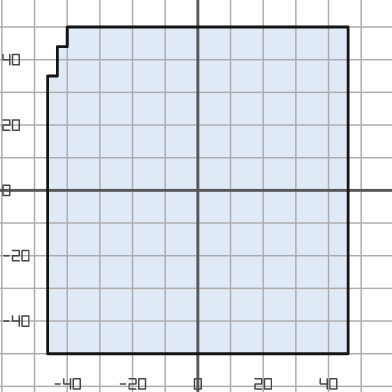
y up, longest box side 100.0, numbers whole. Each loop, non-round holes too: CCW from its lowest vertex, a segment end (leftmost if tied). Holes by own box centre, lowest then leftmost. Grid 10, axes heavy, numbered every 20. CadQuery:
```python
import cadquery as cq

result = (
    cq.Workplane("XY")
    .moveTo(-46.0, -50.0)
    .lineTo(46.0, -50.0)
    .lineTo(46.0, 50.0)
    .lineTo(-40.0, 50.0)
    .lineTo(-40.0, 44.0)
    .lineTo(-43.0, 44.0)
    .lineTo(-43.0, 35.0)
    .lineTo(-46.0, 35.0)
    .close()
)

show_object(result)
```